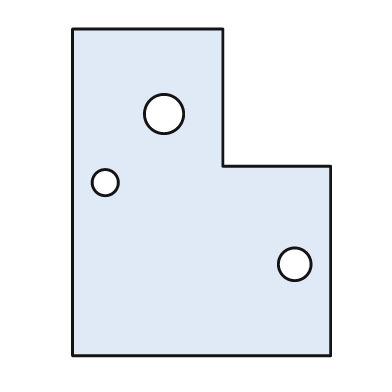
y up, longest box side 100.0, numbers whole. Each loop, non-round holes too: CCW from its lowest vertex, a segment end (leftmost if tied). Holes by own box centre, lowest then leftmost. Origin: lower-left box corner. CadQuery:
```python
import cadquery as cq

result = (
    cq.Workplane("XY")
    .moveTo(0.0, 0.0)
    .lineTo(79.0, 0.0)
    .lineTo(79.0, 58.0)
    .lineTo(46.0, 58.0)
    .lineTo(46.0, 100.0)
    .lineTo(0.0, 100.0)
    .close()
    .moveTo(68.0, 28.0)
    .circle(5.0)
    .moveTo(10.0, 53.0)
    .circle(4.0)
    .moveTo(28.0, 74.0)
    .circle(6.0)
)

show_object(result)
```